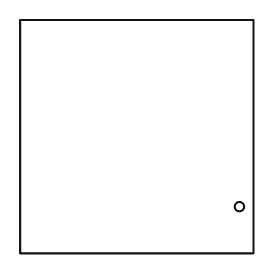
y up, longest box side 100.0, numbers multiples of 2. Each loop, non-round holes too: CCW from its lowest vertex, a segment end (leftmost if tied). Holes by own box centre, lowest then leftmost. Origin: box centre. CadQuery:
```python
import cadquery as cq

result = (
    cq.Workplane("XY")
    .moveTo(-50.0, -50.0)
    .lineTo(50.0, -50.0)
    .lineTo(50.0, 50.0)
    .lineTo(-50.0, 50.0)
    .close()
    .moveTo(44.0, -30.0)
    .circle(2.0)
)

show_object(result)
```